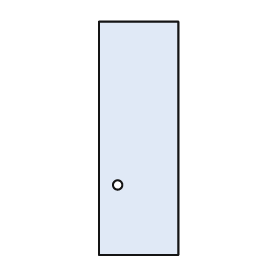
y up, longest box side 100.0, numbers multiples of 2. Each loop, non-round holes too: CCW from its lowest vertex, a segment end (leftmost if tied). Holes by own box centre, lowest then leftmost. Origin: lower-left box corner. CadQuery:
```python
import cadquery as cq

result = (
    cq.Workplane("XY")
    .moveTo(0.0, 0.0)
    .lineTo(34.0, 0.0)
    .lineTo(34.0, 100.0)
    .lineTo(0.0, 100.0)
    .close()
    .moveTo(8.0, 30.0)
    .circle(2.0)
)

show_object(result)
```